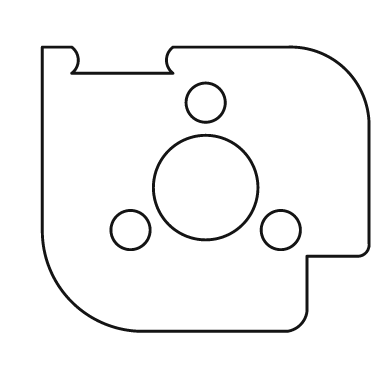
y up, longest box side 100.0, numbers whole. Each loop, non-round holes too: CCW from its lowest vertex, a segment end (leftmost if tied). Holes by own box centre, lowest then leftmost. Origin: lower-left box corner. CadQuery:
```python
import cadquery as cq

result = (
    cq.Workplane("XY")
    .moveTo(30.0, 0.0)
    .lineTo(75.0, 0.0)
    .threePointArc((79.0, 2.0), (81.0, 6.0))
    .lineTo(81.0, 23.0)
    .lineTo(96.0, 23.0)
    .threePointArc((99.0, 24.0), (100.0, 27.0))
    .lineTo(100.0, 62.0)
    .threePointArc((93.0, 80.0), (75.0, 87.0))
    .lineTo(40.0, 87.0)
    .threePointArc((38.0, 83.0), (40.0, 79.0))
    .lineTo(9.0, 79.0)
    .threePointArc((11.0, 83.0), (9.0, 87.0))
    .lineTo(0.0, 87.0)
    .lineTo(0.0, 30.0)
    .threePointArc((9.0, 9.0), (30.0, 0.0))
    .close()
    .moveTo(27.0, 31.0)
    .circle(6.0)
    .moveTo(73.0, 31.0)
    .circle(6.0)
    .moveTo(50.0, 44.0)
    .circle(16.0)
    .moveTo(50.0, 70.0)
    .circle(6.0)
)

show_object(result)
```